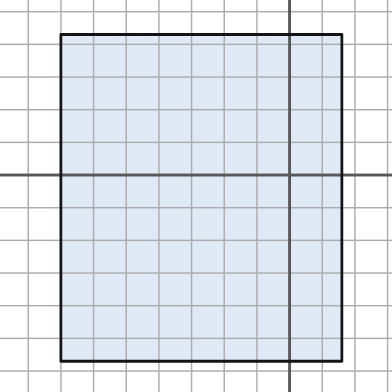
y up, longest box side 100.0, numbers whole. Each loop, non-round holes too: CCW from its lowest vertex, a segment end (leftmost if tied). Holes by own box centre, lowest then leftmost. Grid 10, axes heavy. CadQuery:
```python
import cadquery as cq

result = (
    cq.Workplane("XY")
    .moveTo(-70.0, -57.0)
    .lineTo(16.0, -57.0)
    .lineTo(16.0, 43.0)
    .lineTo(-70.0, 43.0)
    .close()
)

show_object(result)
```